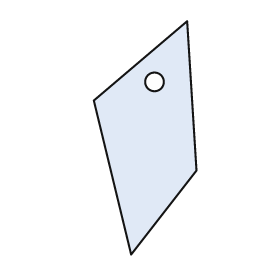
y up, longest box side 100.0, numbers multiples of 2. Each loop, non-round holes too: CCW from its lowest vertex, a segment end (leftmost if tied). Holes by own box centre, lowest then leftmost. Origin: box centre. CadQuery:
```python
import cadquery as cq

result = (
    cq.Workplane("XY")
    .moveTo(-6.0, -50.0)
    .lineTo(22.0, -14.0)
    .lineTo(18.0, 50.0)
    .lineTo(-22.0, 16.0)
    .close()
    .moveTo(4.0, 24.0)
    .circle(4.0)
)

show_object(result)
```